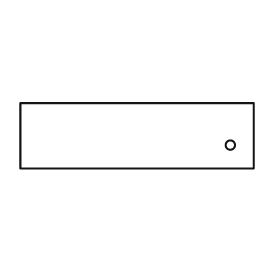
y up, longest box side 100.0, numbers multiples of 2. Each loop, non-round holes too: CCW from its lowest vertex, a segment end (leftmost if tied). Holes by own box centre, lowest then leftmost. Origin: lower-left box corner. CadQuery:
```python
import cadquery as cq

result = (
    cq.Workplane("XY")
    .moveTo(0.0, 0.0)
    .lineTo(100.0, 0.0)
    .lineTo(100.0, 28.0)
    .lineTo(0.0, 28.0)
    .close()
    .moveTo(90.0, 10.0)
    .circle(2.0)
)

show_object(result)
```